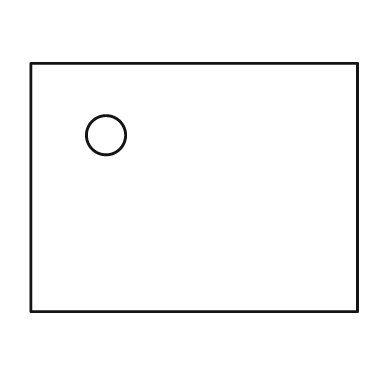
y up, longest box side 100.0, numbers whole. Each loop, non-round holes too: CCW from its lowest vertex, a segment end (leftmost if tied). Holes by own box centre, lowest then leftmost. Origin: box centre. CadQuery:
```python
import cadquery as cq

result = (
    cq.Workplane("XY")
    .moveTo(-50.0, -38.0)
    .lineTo(50.0, -38.0)
    .lineTo(50.0, 38.0)
    .lineTo(-50.0, 38.0)
    .close()
    .moveTo(-27.0, 16.0)
    .circle(6.0)
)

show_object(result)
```